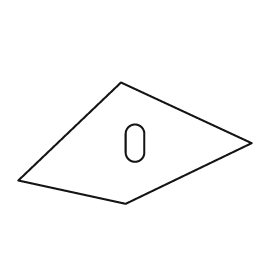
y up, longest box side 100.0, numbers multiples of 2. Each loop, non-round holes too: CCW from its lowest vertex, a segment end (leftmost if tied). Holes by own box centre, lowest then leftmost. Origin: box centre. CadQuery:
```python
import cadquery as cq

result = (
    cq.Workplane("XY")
    .moveTo(-4.0, -26.0)
    .lineTo(50.0, 0.0)
    .lineTo(-6.0, 26.0)
    .lineTo(-50.0, -16.0)
    .close()
    .moveTo(-4.0, -4.0)
    .threePointArc((0.0, -8.0), (4.0, -4.0))
    .lineTo(4.0, 4.0)
    .threePointArc((0.0, 8.0), (-4.0, 4.0))
    .close()
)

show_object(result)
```